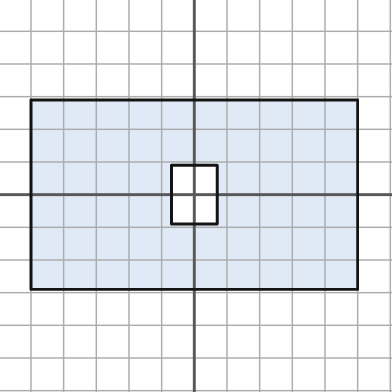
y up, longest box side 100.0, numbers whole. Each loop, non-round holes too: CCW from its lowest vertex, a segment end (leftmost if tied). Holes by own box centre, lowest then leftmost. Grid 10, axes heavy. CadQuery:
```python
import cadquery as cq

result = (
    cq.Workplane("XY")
    .moveTo(-50.0, -29.0)
    .lineTo(50.0, -29.0)
    .lineTo(50.0, 29.0)
    .lineTo(-50.0, 29.0)
    .close()
    .moveTo(-7.0, -9.0)
    .lineTo(7.0, -9.0)
    .lineTo(7.0, 9.0)
    .lineTo(-7.0, 9.0)
    .close()
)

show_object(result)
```